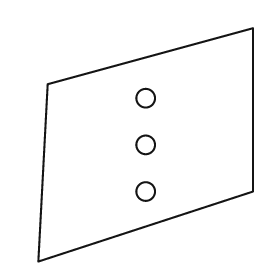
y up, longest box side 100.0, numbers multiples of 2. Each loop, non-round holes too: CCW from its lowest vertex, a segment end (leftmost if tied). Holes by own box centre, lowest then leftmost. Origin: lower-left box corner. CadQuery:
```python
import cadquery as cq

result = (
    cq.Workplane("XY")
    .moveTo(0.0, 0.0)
    .lineTo(92.0, 30.0)
    .lineTo(92.0, 100.0)
    .lineTo(4.0, 76.0)
    .close()
    .moveTo(46.0, 30.0)
    .circle(4.0)
    .moveTo(46.0, 50.0)
    .circle(4.0)
    .moveTo(46.0, 70.0)
    .circle(4.0)
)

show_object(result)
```